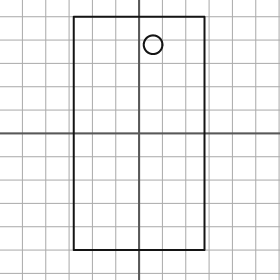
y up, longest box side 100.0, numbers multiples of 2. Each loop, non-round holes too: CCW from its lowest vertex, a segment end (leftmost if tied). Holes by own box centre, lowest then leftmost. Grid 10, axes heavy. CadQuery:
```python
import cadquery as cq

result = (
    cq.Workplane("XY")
    .moveTo(-28.0, -50.0)
    .lineTo(28.0, -50.0)
    .lineTo(28.0, 50.0)
    .lineTo(-28.0, 50.0)
    .close()
    .moveTo(6.0, 38.0)
    .circle(4.0)
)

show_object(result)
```